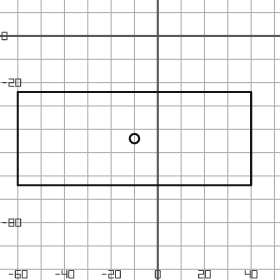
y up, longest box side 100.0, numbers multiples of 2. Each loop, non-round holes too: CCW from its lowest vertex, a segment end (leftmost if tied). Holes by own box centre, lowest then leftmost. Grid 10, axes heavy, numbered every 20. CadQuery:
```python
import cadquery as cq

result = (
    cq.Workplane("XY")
    .moveTo(-60.0, -64.0)
    .lineTo(40.0, -64.0)
    .lineTo(40.0, -24.0)
    .lineTo(-60.0, -24.0)
    .close()
    .moveTo(-10.0, -44.0)
    .circle(2.0)
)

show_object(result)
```